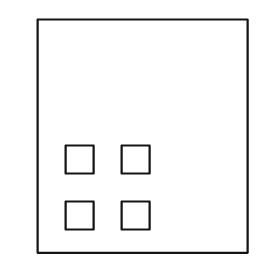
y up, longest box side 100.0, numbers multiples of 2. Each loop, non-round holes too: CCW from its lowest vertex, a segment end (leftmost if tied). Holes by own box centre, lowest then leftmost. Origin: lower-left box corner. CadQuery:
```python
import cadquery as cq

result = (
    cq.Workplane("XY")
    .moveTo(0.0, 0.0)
    .lineTo(90.0, 0.0)
    .lineTo(90.0, 100.0)
    .lineTo(0.0, 100.0)
    .close()
    .moveTo(12.0, 10.0)
    .lineTo(24.0, 10.0)
    .lineTo(24.0, 22.0)
    .lineTo(12.0, 22.0)
    .close()
    .moveTo(36.0, 10.0)
    .lineTo(48.0, 10.0)
    .lineTo(48.0, 22.0)
    .lineTo(36.0, 22.0)
    .close()
    .moveTo(12.0, 34.0)
    .lineTo(24.0, 34.0)
    .lineTo(24.0, 46.0)
    .lineTo(12.0, 46.0)
    .close()
    .moveTo(36.0, 34.0)
    .lineTo(48.0, 34.0)
    .lineTo(48.0, 46.0)
    .lineTo(36.0, 46.0)
    .close()
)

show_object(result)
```